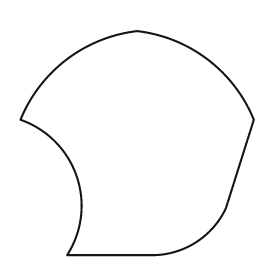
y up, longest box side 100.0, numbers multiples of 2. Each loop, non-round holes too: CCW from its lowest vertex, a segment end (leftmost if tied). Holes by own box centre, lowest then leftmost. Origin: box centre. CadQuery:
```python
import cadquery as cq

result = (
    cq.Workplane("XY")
    .moveTo(-30.0, -48.0)
    .lineTo(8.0, -48.0)
    .threePointArc((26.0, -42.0), (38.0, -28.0))
    .lineTo(50.0, 10.0)
    .threePointArc((30.0, 36.0), (0.0, 48.0))
    .threePointArc((-30.0, 36.0), (-50.0, 10.0))
    .threePointArc((-26.0, -14.0), (-30.0, -48.0))
    .close()
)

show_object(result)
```